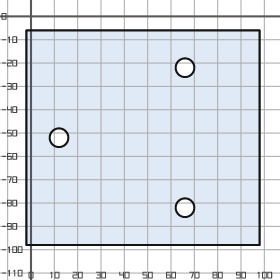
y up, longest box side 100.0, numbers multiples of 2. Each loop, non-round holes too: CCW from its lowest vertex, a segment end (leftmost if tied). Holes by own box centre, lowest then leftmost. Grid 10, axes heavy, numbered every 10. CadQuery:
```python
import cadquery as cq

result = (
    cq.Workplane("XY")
    .moveTo(-2.0, -98.0)
    .lineTo(98.0, -98.0)
    .lineTo(98.0, -6.0)
    .lineTo(-2.0, -6.0)
    .close()
    .moveTo(66.0, -82.0)
    .circle(4.0)
    .moveTo(12.0, -52.0)
    .circle(4.0)
    .moveTo(66.0, -22.0)
    .circle(4.0)
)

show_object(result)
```